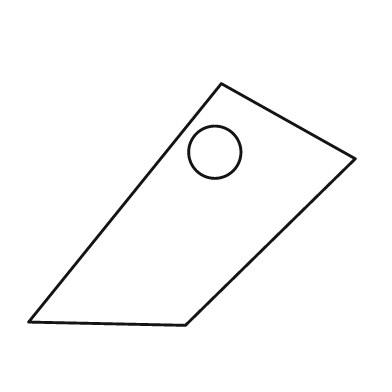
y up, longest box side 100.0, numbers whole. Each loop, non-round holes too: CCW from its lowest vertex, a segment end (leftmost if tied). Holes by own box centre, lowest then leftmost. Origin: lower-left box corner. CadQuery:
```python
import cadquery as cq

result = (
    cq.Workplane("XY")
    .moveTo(48.0, 0.0)
    .lineTo(100.0, 51.0)
    .lineTo(59.0, 74.0)
    .lineTo(0.0, 1.0)
    .close()
    .moveTo(57.0, 53.0)
    .circle(8.0)
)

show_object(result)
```